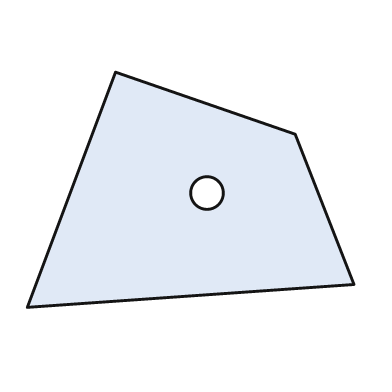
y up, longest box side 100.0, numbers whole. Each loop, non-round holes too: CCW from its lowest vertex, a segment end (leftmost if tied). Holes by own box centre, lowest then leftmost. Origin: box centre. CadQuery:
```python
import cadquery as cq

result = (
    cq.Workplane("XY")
    .moveTo(-50.0, -36.0)
    .lineTo(50.0, -29.0)
    .lineTo(32.0, 17.0)
    .lineTo(-23.0, 36.0)
    .close()
    .moveTo(5.0, -1.0)
    .circle(5.0)
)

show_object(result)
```